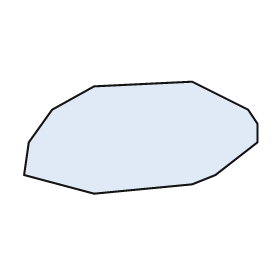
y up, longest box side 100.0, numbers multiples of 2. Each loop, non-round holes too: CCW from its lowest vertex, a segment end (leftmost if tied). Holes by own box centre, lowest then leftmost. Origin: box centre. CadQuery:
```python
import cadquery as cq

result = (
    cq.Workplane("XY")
    .moveTo(-20.0, -24.0)
    .lineTo(22.0, -20.0)
    .lineTo(32.0, -16.0)
    .lineTo(50.0, -2.0)
    .lineTo(50.0, 6.0)
    .lineTo(46.0, 12.0)
    .lineTo(22.0, 24.0)
    .lineTo(-20.0, 22.0)
    .lineTo(-38.0, 12.0)
    .lineTo(-48.0, -2.0)
    .lineTo(-50.0, -16.0)
    .close()
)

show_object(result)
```